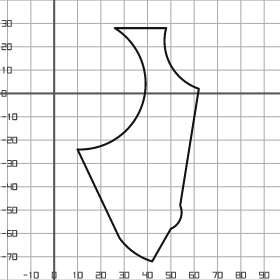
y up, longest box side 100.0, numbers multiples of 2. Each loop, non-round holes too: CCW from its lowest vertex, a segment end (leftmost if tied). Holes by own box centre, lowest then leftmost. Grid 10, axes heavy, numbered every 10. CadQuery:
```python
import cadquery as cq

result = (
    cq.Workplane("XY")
    .moveTo(42.0, -72.0)
    .lineTo(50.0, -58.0)
    .threePointArc((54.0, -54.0), (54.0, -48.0))
    .lineTo(62.0, 2.0)
    .threePointArc((50.0, 12.0), (48.0, 28.0))
    .lineTo(26.0, 28.0)
    .threePointArc((38.0, -4.0), (10.0, -24.0))
    .lineTo(28.0, -62.0)
    .threePointArc((34.0, -68.0), (42.0, -72.0))
    .close()
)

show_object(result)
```